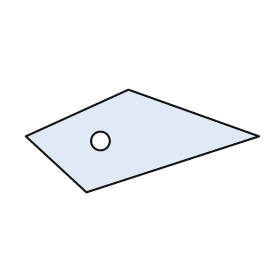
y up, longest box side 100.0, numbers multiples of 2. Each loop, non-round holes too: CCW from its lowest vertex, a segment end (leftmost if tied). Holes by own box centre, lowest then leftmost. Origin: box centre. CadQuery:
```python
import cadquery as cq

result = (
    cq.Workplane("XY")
    .moveTo(-24.0, -22.0)
    .lineTo(50.0, 2.0)
    .lineTo(-6.0, 22.0)
    .lineTo(-50.0, 2.0)
    .close()
    .moveTo(-18.0, 0.0)
    .circle(4.0)
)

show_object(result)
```